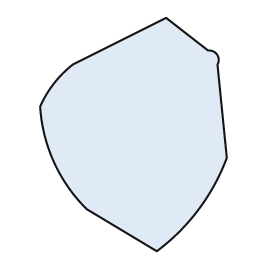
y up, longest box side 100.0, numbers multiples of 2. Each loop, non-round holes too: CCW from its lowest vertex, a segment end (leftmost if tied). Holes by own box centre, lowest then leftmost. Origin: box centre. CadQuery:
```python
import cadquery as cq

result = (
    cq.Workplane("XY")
    .moveTo(10.0, -50.0)
    .threePointArc((28.0, -32.0), (40.0, -10.0))
    .lineTo(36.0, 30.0)
    .threePointArc((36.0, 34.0), (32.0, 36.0))
    .lineTo(14.0, 50.0)
    .lineTo(-26.0, 30.0)
    .threePointArc((-34.0, 22.0), (-40.0, 12.0))
    .threePointArc((-34.0, -12.0), (-20.0, -32.0))
    .close()
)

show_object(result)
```